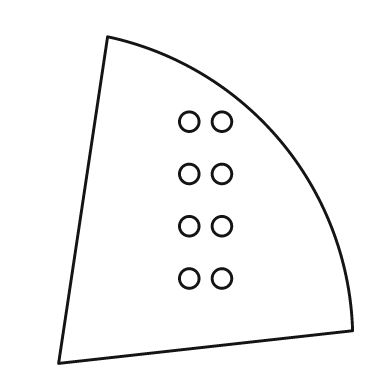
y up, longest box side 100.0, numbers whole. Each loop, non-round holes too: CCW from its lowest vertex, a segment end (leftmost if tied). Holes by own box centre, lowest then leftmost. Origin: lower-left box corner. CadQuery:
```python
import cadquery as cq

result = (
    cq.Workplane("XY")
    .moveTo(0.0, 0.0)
    .lineTo(90.0, 10.0)
    .threePointArc((68.0, 68.0), (15.0, 100.0))
    .close()
    .moveTo(40.0, 26.0)
    .circle(3.0)
    .moveTo(50.0, 26.0)
    .circle(3.0)
    .moveTo(40.0, 42.0)
    .circle(3.0)
    .moveTo(50.0, 42.0)
    .circle(3.0)
    .moveTo(40.0, 58.0)
    .circle(3.0)
    .moveTo(50.0, 58.0)
    .circle(3.0)
    .moveTo(40.0, 74.0)
    .circle(3.0)
    .moveTo(50.0, 74.0)
    .circle(3.0)
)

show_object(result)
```